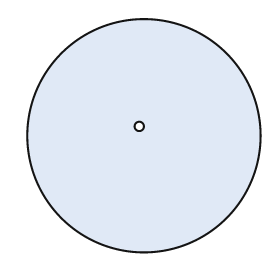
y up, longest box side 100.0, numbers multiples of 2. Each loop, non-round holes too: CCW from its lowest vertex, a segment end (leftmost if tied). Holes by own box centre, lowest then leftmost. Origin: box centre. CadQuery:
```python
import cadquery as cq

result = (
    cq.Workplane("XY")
    .moveTo(0.0, 0.0)
    .circle(50.0)
    .moveTo(-2.0, 4.0)
    .circle(2.0)
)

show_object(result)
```